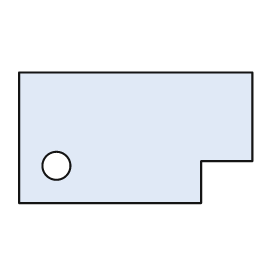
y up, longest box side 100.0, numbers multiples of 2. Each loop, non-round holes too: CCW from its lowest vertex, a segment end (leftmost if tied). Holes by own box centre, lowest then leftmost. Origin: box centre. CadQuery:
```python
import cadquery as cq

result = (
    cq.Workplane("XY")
    .moveTo(-50.0, -28.0)
    .lineTo(28.0, -28.0)
    .lineTo(28.0, -10.0)
    .lineTo(50.0, -10.0)
    .lineTo(50.0, 28.0)
    .lineTo(-50.0, 28.0)
    .close()
    .moveTo(-34.0, -12.0)
    .circle(6.0)
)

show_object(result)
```